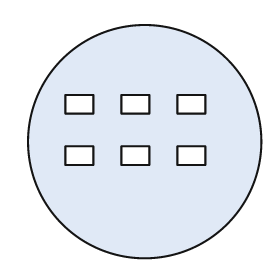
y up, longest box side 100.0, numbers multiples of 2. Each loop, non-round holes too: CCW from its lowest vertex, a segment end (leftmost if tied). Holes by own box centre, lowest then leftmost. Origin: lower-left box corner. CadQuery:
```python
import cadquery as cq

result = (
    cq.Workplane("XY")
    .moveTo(50.0, 50.0)
    .circle(50.0)
    .moveTo(16.0, 40.0)
    .lineTo(28.0, 40.0)
    .lineTo(28.0, 48.0)
    .lineTo(16.0, 48.0)
    .close()
    .moveTo(40.0, 40.0)
    .lineTo(52.0, 40.0)
    .lineTo(52.0, 48.0)
    .lineTo(40.0, 48.0)
    .close()
    .moveTo(64.0, 40.0)
    .lineTo(76.0, 40.0)
    .lineTo(76.0, 48.0)
    .lineTo(64.0, 48.0)
    .close()
    .moveTo(16.0, 62.0)
    .lineTo(28.0, 62.0)
    .lineTo(28.0, 70.0)
    .lineTo(16.0, 70.0)
    .close()
    .moveTo(40.0, 62.0)
    .lineTo(52.0, 62.0)
    .lineTo(52.0, 70.0)
    .lineTo(40.0, 70.0)
    .close()
    .moveTo(64.0, 62.0)
    .lineTo(76.0, 62.0)
    .lineTo(76.0, 70.0)
    .lineTo(64.0, 70.0)
    .close()
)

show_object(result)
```